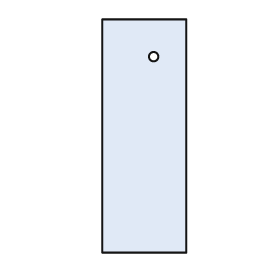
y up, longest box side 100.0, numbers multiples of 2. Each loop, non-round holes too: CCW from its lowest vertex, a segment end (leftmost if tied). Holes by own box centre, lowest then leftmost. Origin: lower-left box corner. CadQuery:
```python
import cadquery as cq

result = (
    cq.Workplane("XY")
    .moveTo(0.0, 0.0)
    .lineTo(36.0, 0.0)
    .lineTo(36.0, 100.0)
    .lineTo(0.0, 100.0)
    .close()
    .moveTo(22.0, 84.0)
    .circle(2.0)
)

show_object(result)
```